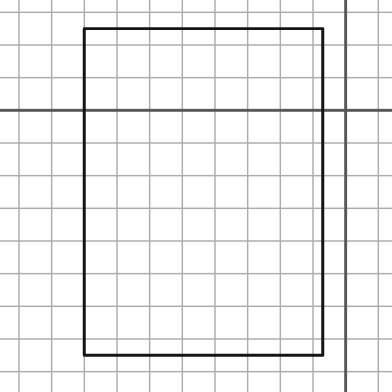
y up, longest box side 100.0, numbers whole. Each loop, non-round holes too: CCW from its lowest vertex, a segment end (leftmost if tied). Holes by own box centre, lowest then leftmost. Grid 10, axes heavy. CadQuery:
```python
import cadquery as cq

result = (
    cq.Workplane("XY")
    .moveTo(-80.0, -75.0)
    .lineTo(-7.0, -75.0)
    .lineTo(-7.0, 25.0)
    .lineTo(-80.0, 25.0)
    .close()
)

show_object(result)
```